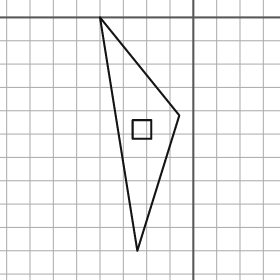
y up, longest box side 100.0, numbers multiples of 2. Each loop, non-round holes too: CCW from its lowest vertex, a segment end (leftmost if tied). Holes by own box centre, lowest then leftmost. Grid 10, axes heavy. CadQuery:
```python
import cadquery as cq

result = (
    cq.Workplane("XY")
    .moveTo(-24.0, -100.0)
    .lineTo(-6.0, -42.0)
    .lineTo(-40.0, 0.0)
    .close()
    .moveTo(-26.0, -52.0)
    .lineTo(-18.0, -52.0)
    .lineTo(-18.0, -44.0)
    .lineTo(-26.0, -44.0)
    .close()
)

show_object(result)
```